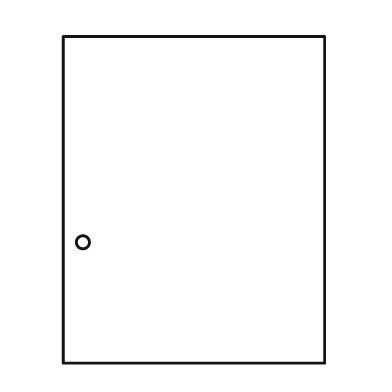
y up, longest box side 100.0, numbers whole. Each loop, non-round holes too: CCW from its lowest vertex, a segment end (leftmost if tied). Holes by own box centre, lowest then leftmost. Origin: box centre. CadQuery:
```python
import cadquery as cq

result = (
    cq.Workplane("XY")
    .moveTo(-40.0, -50.0)
    .lineTo(40.0, -50.0)
    .lineTo(40.0, 50.0)
    .lineTo(-40.0, 50.0)
    .close()
    .moveTo(-34.0, -13.0)
    .circle(2.0)
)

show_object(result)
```